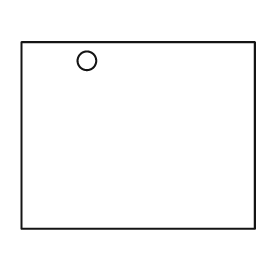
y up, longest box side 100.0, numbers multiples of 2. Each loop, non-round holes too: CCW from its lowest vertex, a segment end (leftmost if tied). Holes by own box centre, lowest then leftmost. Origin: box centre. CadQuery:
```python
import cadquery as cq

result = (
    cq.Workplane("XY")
    .moveTo(-50.0, -40.0)
    .lineTo(50.0, -40.0)
    .lineTo(50.0, 40.0)
    .lineTo(-50.0, 40.0)
    .close()
    .moveTo(-22.0, 32.0)
    .circle(4.0)
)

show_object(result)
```